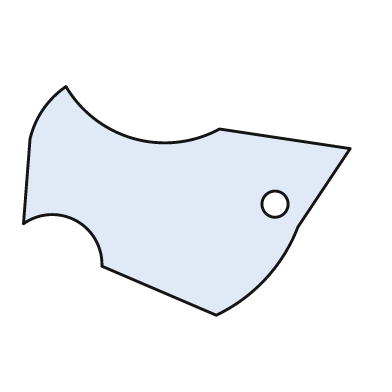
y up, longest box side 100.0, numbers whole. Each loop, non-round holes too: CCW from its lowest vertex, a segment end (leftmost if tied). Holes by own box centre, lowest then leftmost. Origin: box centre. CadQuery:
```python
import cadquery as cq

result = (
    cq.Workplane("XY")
    .moveTo(9.0, -35.0)
    .threePointArc((24.0, -24.0), (34.0, -8.0))
    .lineTo(50.0, 16.0)
    .lineTo(10.0, 22.0)
    .threePointArc((-16.0, 19.0), (-37.0, 35.0))
    .threePointArc((-44.0, 28.0), (-48.0, 19.0))
    .lineTo(-50.0, -7.0)
    .threePointArc((-34.0, -6.0), (-26.0, -20.0))
    .close()
    .moveTo(27.0, -1.0)
    .circle(4.0)
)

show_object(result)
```